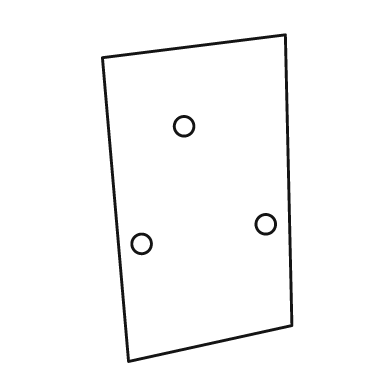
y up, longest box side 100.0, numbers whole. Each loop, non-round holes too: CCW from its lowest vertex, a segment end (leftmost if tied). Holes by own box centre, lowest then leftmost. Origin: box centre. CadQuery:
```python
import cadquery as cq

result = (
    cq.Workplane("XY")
    .moveTo(-21.0, -50.0)
    .lineTo(29.0, -39.0)
    .lineTo(27.0, 50.0)
    .lineTo(-29.0, 43.0)
    .close()
    .moveTo(-17.0, -14.0)
    .circle(3.0)
    .moveTo(21.0, -8.0)
    .circle(3.0)
    .moveTo(-4.0, 22.0)
    .circle(3.0)
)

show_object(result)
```